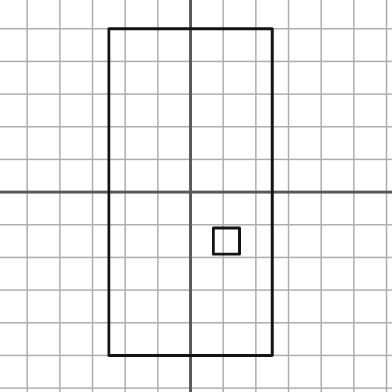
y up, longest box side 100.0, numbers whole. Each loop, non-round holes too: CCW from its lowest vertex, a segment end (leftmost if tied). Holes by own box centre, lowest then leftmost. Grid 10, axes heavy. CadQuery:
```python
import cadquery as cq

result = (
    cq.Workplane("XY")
    .moveTo(-25.0, -50.0)
    .lineTo(25.0, -50.0)
    .lineTo(25.0, 50.0)
    .lineTo(-25.0, 50.0)
    .close()
    .moveTo(7.0, -19.0)
    .lineTo(15.0, -19.0)
    .lineTo(15.0, -11.0)
    .lineTo(7.0, -11.0)
    .close()
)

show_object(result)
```